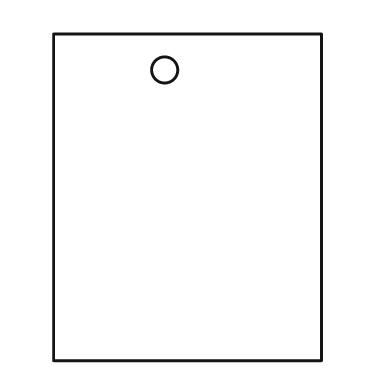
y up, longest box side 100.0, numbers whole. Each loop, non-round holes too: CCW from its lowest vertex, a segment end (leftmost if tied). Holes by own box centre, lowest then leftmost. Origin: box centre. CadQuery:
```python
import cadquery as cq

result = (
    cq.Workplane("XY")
    .moveTo(-41.0, -50.0)
    .lineTo(41.0, -50.0)
    .lineTo(41.0, 50.0)
    .lineTo(-41.0, 50.0)
    .close()
    .moveTo(-7.0, 39.0)
    .circle(4.0)
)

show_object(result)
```